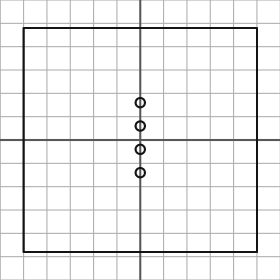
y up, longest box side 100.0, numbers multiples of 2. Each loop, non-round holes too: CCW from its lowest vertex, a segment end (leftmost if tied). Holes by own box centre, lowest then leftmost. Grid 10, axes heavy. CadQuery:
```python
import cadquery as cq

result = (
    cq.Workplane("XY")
    .moveTo(-50.0, -48.0)
    .lineTo(50.0, -48.0)
    .lineTo(50.0, 48.0)
    .lineTo(-50.0, 48.0)
    .close()
    .moveTo(0.0, -14.0)
    .circle(2.0)
    .moveTo(0.0, -4.0)
    .circle(2.0)
    .moveTo(0.0, 6.0)
    .circle(2.0)
    .moveTo(0.0, 16.0)
    .circle(2.0)
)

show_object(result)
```